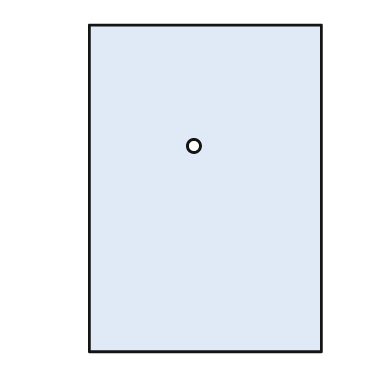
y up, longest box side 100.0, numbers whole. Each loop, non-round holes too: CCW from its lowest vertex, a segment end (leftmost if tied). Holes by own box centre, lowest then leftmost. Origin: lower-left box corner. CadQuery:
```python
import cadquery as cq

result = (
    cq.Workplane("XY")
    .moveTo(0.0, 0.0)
    .lineTo(71.0, 0.0)
    .lineTo(71.0, 100.0)
    .lineTo(0.0, 100.0)
    .close()
    .moveTo(32.0, 63.0)
    .circle(2.0)
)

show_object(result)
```